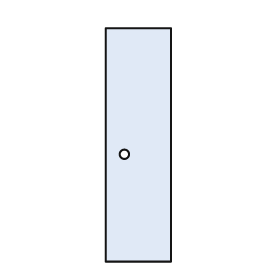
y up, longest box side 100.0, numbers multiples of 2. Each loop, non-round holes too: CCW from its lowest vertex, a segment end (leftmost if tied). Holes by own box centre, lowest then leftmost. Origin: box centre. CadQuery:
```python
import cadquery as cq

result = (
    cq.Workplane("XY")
    .moveTo(-14.0, -50.0)
    .lineTo(14.0, -50.0)
    .lineTo(14.0, 50.0)
    .lineTo(-14.0, 50.0)
    .close()
    .moveTo(-6.0, -4.0)
    .circle(2.0)
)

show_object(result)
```